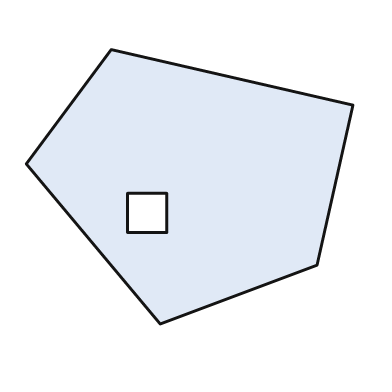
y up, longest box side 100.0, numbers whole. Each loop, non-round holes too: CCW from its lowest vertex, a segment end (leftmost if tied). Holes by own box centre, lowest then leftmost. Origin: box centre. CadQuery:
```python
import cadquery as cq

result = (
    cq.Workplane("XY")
    .moveTo(-9.0, -42.0)
    .lineTo(39.0, -24.0)
    .lineTo(50.0, 25.0)
    .lineTo(-24.0, 42.0)
    .lineTo(-50.0, 7.0)
    .close()
    .moveTo(-19.0, -14.0)
    .lineTo(-7.0, -14.0)
    .lineTo(-7.0, -2.0)
    .lineTo(-19.0, -2.0)
    .close()
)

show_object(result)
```